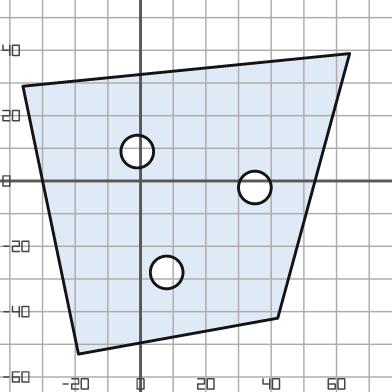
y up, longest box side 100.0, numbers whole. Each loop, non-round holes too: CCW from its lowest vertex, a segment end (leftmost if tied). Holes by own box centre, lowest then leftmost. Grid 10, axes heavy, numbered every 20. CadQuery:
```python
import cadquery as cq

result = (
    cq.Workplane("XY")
    .moveTo(-19.0, -53.0)
    .lineTo(42.0, -42.0)
    .lineTo(64.0, 39.0)
    .lineTo(-36.0, 29.0)
    .close()
    .moveTo(8.0, -28.0)
    .circle(5.0)
    .moveTo(35.0, -2.0)
    .circle(5.0)
    .moveTo(-1.0, 9.0)
    .circle(5.0)
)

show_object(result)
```